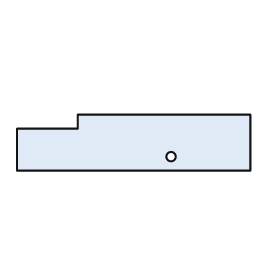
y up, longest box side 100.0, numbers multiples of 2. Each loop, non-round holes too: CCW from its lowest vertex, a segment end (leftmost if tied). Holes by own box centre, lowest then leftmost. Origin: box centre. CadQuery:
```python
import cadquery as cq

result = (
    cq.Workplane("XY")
    .moveTo(-50.0, -12.0)
    .lineTo(50.0, -12.0)
    .lineTo(50.0, 12.0)
    .lineTo(-24.0, 12.0)
    .lineTo(-24.0, 6.0)
    .lineTo(-50.0, 6.0)
    .close()
    .moveTo(16.0, -6.0)
    .circle(2.0)
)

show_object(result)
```